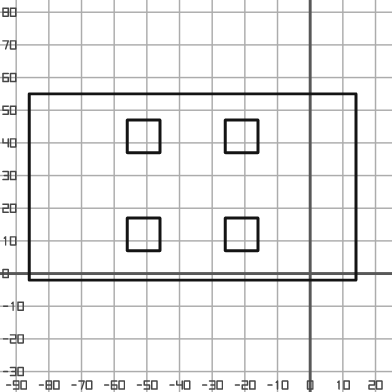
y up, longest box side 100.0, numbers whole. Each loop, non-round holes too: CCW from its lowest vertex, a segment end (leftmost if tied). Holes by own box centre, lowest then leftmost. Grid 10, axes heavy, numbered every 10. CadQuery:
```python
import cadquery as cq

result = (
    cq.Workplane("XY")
    .moveTo(-86.0, -2.0)
    .lineTo(14.0, -2.0)
    .lineTo(14.0, 55.0)
    .lineTo(-86.0, 55.0)
    .close()
    .moveTo(-56.0, 7.0)
    .lineTo(-46.0, 7.0)
    .lineTo(-46.0, 17.0)
    .lineTo(-56.0, 17.0)
    .close()
    .moveTo(-26.0, 7.0)
    .lineTo(-16.0, 7.0)
    .lineTo(-16.0, 17.0)
    .lineTo(-26.0, 17.0)
    .close()
    .moveTo(-56.0, 37.0)
    .lineTo(-46.0, 37.0)
    .lineTo(-46.0, 47.0)
    .lineTo(-56.0, 47.0)
    .close()
    .moveTo(-26.0, 37.0)
    .lineTo(-16.0, 37.0)
    .lineTo(-16.0, 47.0)
    .lineTo(-26.0, 47.0)
    .close()
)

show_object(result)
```